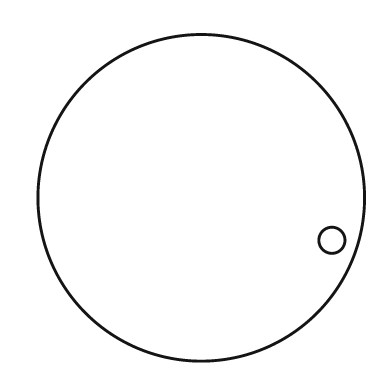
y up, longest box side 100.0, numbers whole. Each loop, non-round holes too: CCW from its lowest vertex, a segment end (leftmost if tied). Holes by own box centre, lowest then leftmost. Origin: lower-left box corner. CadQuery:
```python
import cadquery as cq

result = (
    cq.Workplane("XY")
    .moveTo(50.0, 50.0)
    .circle(50.0)
    .moveTo(90.0, 37.0)
    .circle(4.0)
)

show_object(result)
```